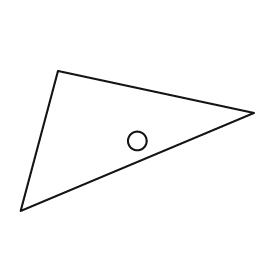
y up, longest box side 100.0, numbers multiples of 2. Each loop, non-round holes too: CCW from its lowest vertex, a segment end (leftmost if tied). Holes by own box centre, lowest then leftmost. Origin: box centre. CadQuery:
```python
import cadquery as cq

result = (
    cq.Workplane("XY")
    .moveTo(-50.0, -30.0)
    .lineTo(50.0, 12.0)
    .lineTo(-34.0, 30.0)
    .close()
    .moveTo(0.0, 0.0)
    .circle(4.0)
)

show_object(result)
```